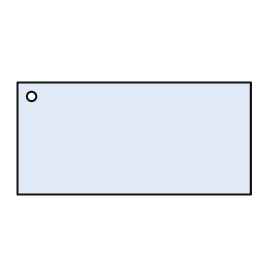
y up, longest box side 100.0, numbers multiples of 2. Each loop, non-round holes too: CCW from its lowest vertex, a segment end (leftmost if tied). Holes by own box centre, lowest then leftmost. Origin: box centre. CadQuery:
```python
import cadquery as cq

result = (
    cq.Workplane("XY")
    .moveTo(-50.0, -24.0)
    .lineTo(50.0, -24.0)
    .lineTo(50.0, 24.0)
    .lineTo(-50.0, 24.0)
    .close()
    .moveTo(-44.0, 18.0)
    .circle(2.0)
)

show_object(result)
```